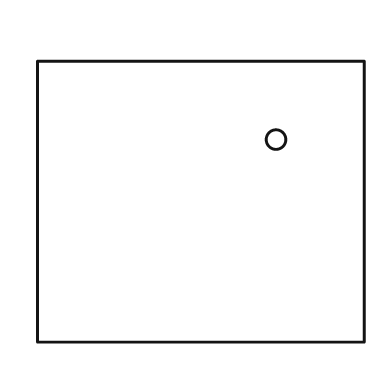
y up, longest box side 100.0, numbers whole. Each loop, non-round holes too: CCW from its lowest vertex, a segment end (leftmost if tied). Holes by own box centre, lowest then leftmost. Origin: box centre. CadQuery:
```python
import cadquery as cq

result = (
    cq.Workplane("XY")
    .moveTo(-50.0, -43.0)
    .lineTo(50.0, -43.0)
    .lineTo(50.0, 43.0)
    .lineTo(-50.0, 43.0)
    .close()
    .moveTo(23.0, 19.0)
    .circle(3.0)
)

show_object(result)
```